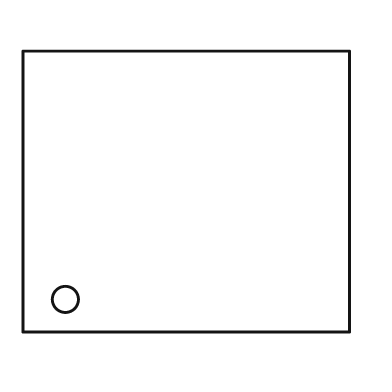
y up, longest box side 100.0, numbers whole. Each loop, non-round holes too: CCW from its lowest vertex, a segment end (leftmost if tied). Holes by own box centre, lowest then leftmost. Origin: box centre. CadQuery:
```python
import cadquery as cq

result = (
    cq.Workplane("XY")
    .moveTo(-50.0, -43.0)
    .lineTo(50.0, -43.0)
    .lineTo(50.0, 43.0)
    .lineTo(-50.0, 43.0)
    .close()
    .moveTo(-37.0, -33.0)
    .circle(4.0)
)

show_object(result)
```